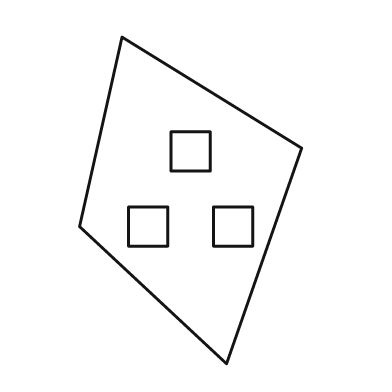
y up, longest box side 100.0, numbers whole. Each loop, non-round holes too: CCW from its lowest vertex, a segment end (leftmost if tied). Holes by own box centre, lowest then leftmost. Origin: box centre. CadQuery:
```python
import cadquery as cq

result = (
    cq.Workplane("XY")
    .moveTo(11.0, -50.0)
    .lineTo(34.0, 16.0)
    .lineTo(-21.0, 50.0)
    .lineTo(-34.0, -8.0)
    .close()
    .moveTo(-19.0, -14.0)
    .lineTo(-7.0, -14.0)
    .lineTo(-7.0, -2.0)
    .lineTo(-19.0, -2.0)
    .close()
    .moveTo(7.0, -14.0)
    .lineTo(19.0, -14.0)
    .lineTo(19.0, -2.0)
    .lineTo(7.0, -2.0)
    .close()
    .moveTo(-6.0, 9.0)
    .lineTo(6.0, 9.0)
    .lineTo(6.0, 21.0)
    .lineTo(-6.0, 21.0)
    .close()
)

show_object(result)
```